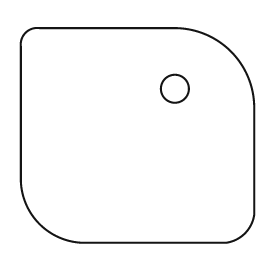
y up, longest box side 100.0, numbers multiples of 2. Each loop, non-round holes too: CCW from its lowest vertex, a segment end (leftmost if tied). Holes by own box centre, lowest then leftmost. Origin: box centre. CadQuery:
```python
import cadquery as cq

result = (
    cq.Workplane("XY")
    .moveTo(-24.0, -46.0)
    .lineTo(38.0, -46.0)
    .threePointArc((46.0, -42.0), (50.0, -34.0))
    .lineTo(50.0, 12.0)
    .threePointArc((40.0, 36.0), (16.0, 46.0))
    .lineTo(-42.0, 46.0)
    .threePointArc((-48.0, 44.0), (-50.0, 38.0))
    .lineTo(-50.0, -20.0)
    .threePointArc((-42.0, -38.0), (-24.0, -46.0))
    .close()
    .moveTo(16.0, 20.0)
    .circle(6.0)
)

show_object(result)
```